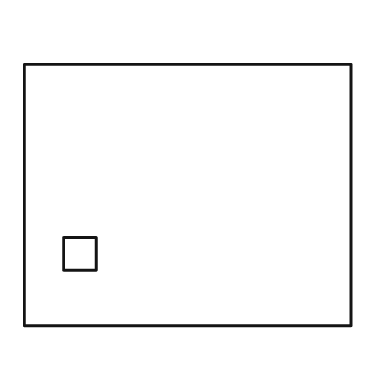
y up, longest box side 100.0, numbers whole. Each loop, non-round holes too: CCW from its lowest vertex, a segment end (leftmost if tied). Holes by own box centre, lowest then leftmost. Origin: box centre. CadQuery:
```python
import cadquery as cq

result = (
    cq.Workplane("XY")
    .moveTo(-50.0, -40.0)
    .lineTo(50.0, -40.0)
    .lineTo(50.0, 40.0)
    .lineTo(-50.0, 40.0)
    .close()
    .moveTo(-38.0, -23.0)
    .lineTo(-28.0, -23.0)
    .lineTo(-28.0, -13.0)
    .lineTo(-38.0, -13.0)
    .close()
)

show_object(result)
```